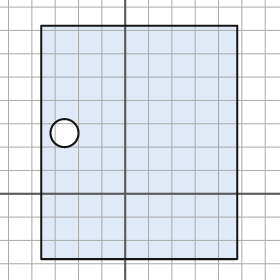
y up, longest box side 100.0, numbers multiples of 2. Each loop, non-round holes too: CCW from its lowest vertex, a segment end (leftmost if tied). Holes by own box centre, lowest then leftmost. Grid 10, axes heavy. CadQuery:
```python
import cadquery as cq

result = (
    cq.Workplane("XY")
    .moveTo(-36.0, -28.0)
    .lineTo(48.0, -28.0)
    .lineTo(48.0, 72.0)
    .lineTo(-36.0, 72.0)
    .close()
    .moveTo(-26.0, 26.0)
    .circle(6.0)
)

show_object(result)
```